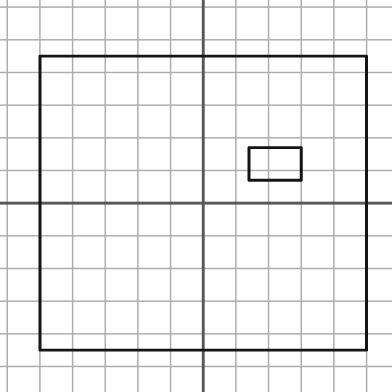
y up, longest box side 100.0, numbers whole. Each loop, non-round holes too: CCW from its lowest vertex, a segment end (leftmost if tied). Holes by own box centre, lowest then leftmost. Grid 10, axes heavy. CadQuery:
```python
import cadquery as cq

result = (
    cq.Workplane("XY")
    .moveTo(-50.0, -45.0)
    .lineTo(50.0, -45.0)
    .lineTo(50.0, 45.0)
    .lineTo(-50.0, 45.0)
    .close()
    .moveTo(14.0, 7.0)
    .lineTo(30.0, 7.0)
    .lineTo(30.0, 17.0)
    .lineTo(14.0, 17.0)
    .close()
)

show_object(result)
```